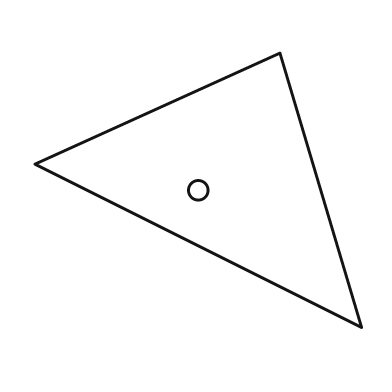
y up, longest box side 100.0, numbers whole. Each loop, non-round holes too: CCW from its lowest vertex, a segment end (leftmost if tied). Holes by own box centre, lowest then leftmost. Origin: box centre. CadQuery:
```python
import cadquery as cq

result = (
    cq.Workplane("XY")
    .moveTo(50.0, -42.0)
    .lineTo(25.0, 42.0)
    .lineTo(-50.0, 8.0)
    .close()
    .moveTo(0.0, 0.0)
    .circle(3.0)
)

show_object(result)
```